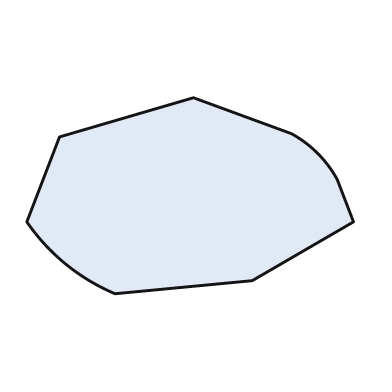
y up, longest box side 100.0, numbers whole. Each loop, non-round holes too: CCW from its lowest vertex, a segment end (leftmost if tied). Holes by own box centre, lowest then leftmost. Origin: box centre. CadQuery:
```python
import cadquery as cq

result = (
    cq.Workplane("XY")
    .moveTo(-23.0, -30.0)
    .lineTo(19.0, -26.0)
    .lineTo(50.0, -8.0)
    .lineTo(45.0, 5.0)
    .threePointArc((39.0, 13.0), (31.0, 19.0))
    .lineTo(1.0, 30.0)
    .lineTo(-40.0, 18.0)
    .lineTo(-50.0, -8.0)
    .threePointArc((-38.0, -21.0), (-23.0, -30.0))
    .close()
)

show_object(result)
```